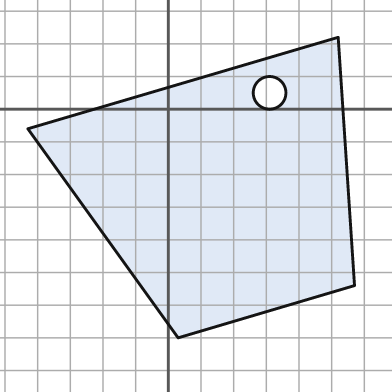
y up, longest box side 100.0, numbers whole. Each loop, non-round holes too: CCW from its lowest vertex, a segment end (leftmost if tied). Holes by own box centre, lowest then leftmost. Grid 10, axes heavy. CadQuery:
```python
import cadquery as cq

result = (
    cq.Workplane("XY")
    .moveTo(3.0, -70.0)
    .lineTo(57.0, -54.0)
    .lineTo(52.0, 22.0)
    .lineTo(-43.0, -6.0)
    .close()
    .moveTo(31.0, 5.0)
    .circle(5.0)
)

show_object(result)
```